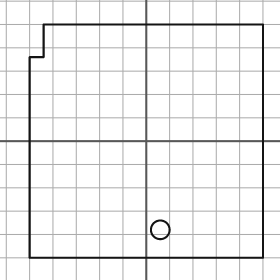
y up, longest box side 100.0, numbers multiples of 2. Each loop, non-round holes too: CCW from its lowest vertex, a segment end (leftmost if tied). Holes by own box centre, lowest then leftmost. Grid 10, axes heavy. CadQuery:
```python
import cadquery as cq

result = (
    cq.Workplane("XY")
    .moveTo(-50.0, -50.0)
    .lineTo(50.0, -50.0)
    .lineTo(50.0, 50.0)
    .lineTo(-44.0, 50.0)
    .lineTo(-44.0, 36.0)
    .lineTo(-50.0, 36.0)
    .close()
    .moveTo(6.0, -38.0)
    .circle(4.0)
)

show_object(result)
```